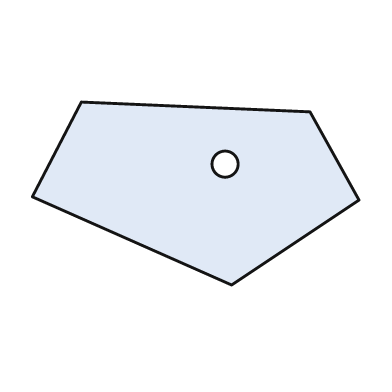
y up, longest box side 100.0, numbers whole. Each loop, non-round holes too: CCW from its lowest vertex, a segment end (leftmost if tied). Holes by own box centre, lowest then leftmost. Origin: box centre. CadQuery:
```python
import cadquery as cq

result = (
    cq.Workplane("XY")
    .moveTo(11.0, -28.0)
    .lineTo(50.0, -2.0)
    .lineTo(35.0, 25.0)
    .lineTo(-35.0, 28.0)
    .lineTo(-50.0, -1.0)
    .close()
    .moveTo(9.0, 9.0)
    .circle(4.0)
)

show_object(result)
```